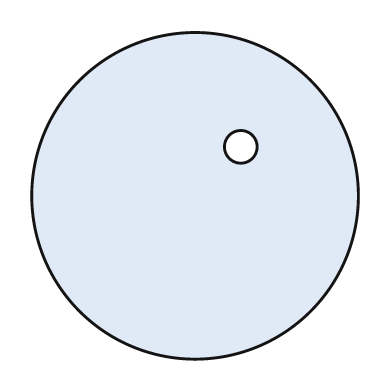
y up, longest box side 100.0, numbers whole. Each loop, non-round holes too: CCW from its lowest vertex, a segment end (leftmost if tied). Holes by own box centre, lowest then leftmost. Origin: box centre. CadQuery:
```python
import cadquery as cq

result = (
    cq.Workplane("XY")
    .moveTo(0.0, 0.0)
    .circle(50.0)
    .moveTo(14.0, 15.0)
    .circle(5.0)
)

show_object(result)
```